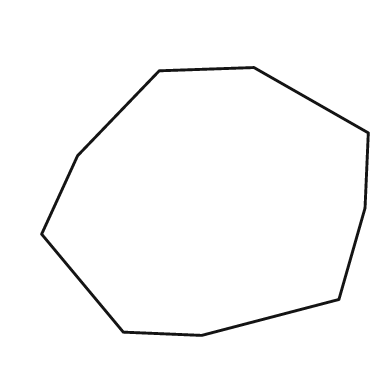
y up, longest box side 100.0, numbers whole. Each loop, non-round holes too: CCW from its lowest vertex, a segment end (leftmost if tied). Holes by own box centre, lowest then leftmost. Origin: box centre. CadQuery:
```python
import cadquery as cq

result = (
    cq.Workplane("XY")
    .moveTo(-1.0, -41.0)
    .lineTo(41.0, -30.0)
    .lineTo(49.0, -2.0)
    .lineTo(50.0, 21.0)
    .lineTo(15.0, 41.0)
    .lineTo(-14.0, 40.0)
    .lineTo(-39.0, 14.0)
    .lineTo(-50.0, -10.0)
    .lineTo(-25.0, -40.0)
    .close()
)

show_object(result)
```